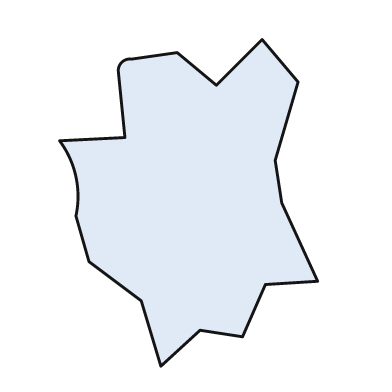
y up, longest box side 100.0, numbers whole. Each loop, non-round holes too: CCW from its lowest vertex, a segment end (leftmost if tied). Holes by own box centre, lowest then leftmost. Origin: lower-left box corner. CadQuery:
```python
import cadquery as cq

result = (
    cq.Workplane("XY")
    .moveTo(31.0, 0.0)
    .lineTo(43.0, 11.0)
    .lineTo(56.0, 9.0)
    .lineTo(63.0, 25.0)
    .lineTo(79.0, 26.0)
    .lineTo(68.0, 50.0)
    .lineTo(66.0, 63.0)
    .lineTo(73.0, 87.0)
    .lineTo(62.0, 100.0)
    .lineTo(48.0, 86.0)
    .lineTo(36.0, 96.0)
    .lineTo(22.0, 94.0)
    .threePointArc((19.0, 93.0), (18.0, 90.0))
    .lineTo(20.0, 70.0)
    .lineTo(0.0, 69.0)
    .threePointArc((5.0, 58.0), (5.0, 46.0))
    .lineTo(9.0, 32.0)
    .lineTo(25.0, 20.0)
    .close()
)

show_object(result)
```